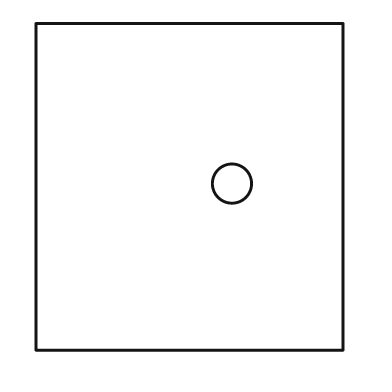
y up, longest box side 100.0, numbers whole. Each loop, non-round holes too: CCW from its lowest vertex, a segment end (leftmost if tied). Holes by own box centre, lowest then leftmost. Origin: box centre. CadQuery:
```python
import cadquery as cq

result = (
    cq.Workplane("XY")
    .moveTo(-47.0, -50.0)
    .lineTo(47.0, -50.0)
    .lineTo(47.0, 50.0)
    .lineTo(-47.0, 50.0)
    .close()
    .moveTo(13.0, 1.0)
    .circle(6.0)
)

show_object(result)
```